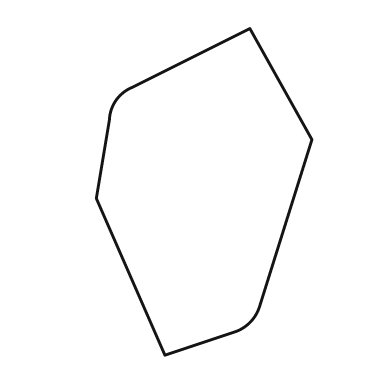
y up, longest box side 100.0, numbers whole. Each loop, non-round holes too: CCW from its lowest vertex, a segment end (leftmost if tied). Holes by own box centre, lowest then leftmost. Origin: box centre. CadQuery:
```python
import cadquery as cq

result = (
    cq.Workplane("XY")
    .moveTo(-12.0, -50.0)
    .lineTo(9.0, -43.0)
    .threePointArc((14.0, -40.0), (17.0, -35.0))
    .lineTo(33.0, 16.0)
    .lineTo(14.0, 50.0)
    .lineTo(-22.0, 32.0)
    .threePointArc((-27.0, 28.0), (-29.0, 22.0))
    .lineTo(-33.0, -2.0)
    .close()
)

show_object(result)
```